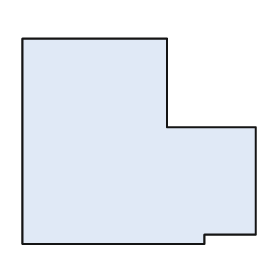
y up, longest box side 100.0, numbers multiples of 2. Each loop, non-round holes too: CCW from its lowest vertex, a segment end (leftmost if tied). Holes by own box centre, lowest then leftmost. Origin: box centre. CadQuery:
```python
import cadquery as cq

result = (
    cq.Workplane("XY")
    .moveTo(-50.0, -44.0)
    .lineTo(28.0, -44.0)
    .lineTo(28.0, -40.0)
    .lineTo(50.0, -40.0)
    .lineTo(50.0, 6.0)
    .lineTo(12.0, 6.0)
    .lineTo(12.0, 44.0)
    .lineTo(-50.0, 44.0)
    .close()
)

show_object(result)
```